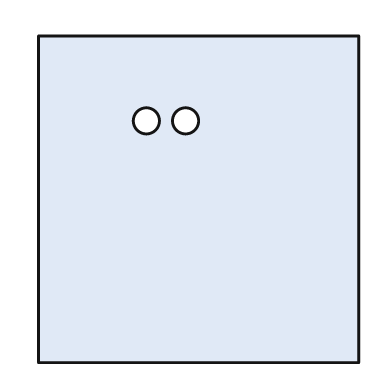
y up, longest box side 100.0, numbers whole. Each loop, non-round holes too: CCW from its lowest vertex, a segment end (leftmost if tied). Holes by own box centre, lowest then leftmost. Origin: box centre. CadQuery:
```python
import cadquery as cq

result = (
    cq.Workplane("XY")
    .moveTo(-49.0, -50.0)
    .lineTo(49.0, -50.0)
    .lineTo(49.0, 50.0)
    .lineTo(-49.0, 50.0)
    .close()
    .moveTo(-16.0, 24.0)
    .circle(4.0)
    .moveTo(-4.0, 24.0)
    .circle(4.0)
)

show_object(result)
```